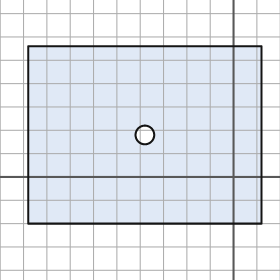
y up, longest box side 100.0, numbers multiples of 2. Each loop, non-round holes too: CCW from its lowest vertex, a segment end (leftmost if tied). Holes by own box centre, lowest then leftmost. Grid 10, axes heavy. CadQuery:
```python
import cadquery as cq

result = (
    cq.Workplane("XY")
    .moveTo(-88.0, -20.0)
    .lineTo(12.0, -20.0)
    .lineTo(12.0, 56.0)
    .lineTo(-88.0, 56.0)
    .close()
    .moveTo(-38.0, 18.0)
    .circle(4.0)
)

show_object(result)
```